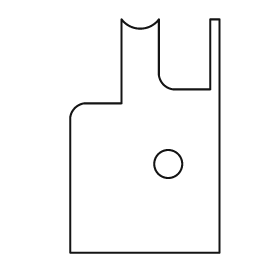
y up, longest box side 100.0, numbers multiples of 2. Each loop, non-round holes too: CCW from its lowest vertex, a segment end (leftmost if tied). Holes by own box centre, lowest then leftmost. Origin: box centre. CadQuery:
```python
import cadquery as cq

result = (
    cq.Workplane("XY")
    .moveTo(-32.0, -50.0)
    .lineTo(32.0, -50.0)
    .lineTo(32.0, 50.0)
    .lineTo(28.0, 50.0)
    .lineTo(28.0, 20.0)
    .lineTo(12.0, 20.0)
    .threePointArc((8.0, 22.0), (6.0, 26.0))
    .lineTo(6.0, 50.0)
    .threePointArc((-2.0, 46.0), (-10.0, 50.0))
    .lineTo(-10.0, 14.0)
    .lineTo(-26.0, 14.0)
    .threePointArc((-30.0, 12.0), (-32.0, 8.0))
    .close()
    .moveTo(10.0, -12.0)
    .circle(6.0)
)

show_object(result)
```